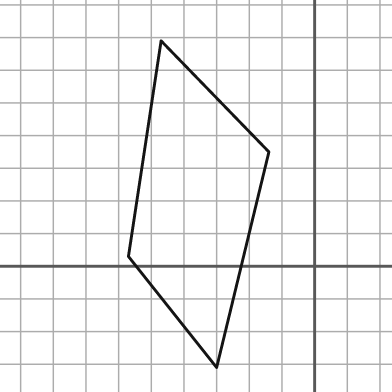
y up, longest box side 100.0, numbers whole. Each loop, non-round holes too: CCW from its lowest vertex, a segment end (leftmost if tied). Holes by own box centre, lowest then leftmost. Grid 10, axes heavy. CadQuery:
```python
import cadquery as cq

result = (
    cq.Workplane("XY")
    .moveTo(-30.0, -31.0)
    .lineTo(-14.0, 35.0)
    .lineTo(-47.0, 69.0)
    .lineTo(-57.0, 3.0)
    .close()
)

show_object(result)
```